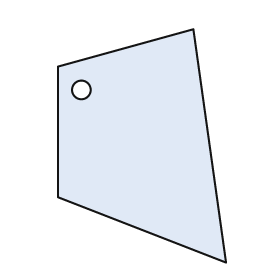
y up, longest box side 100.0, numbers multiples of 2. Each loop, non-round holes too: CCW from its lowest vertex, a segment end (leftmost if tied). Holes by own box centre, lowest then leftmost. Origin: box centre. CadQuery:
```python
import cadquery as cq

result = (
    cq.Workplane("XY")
    .moveTo(36.0, -50.0)
    .lineTo(22.0, 50.0)
    .lineTo(-36.0, 34.0)
    .lineTo(-36.0, -22.0)
    .close()
    .moveTo(-26.0, 24.0)
    .circle(4.0)
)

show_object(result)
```